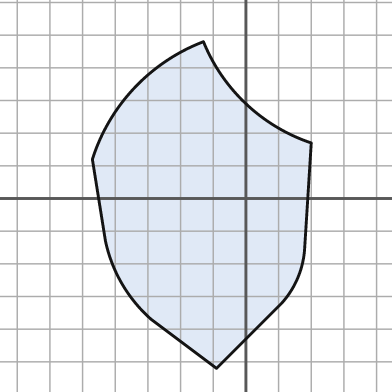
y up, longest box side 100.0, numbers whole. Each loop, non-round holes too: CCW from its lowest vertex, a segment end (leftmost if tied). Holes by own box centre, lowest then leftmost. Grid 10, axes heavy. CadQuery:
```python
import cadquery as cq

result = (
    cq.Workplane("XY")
    .moveTo(-9.0, -52.0)
    .lineTo(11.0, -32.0)
    .threePointArc((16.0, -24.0), (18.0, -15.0))
    .lineTo(20.0, 17.0)
    .threePointArc((0.0, 29.0), (-13.0, 48.0))
    .threePointArc((-34.0, 34.0), (-47.0, 12.0))
    .lineTo(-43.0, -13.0)
    .threePointArc((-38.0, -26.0), (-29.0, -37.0))
    .close()
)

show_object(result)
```